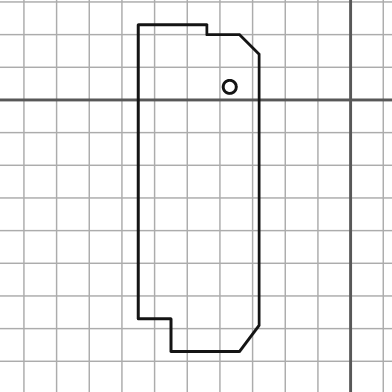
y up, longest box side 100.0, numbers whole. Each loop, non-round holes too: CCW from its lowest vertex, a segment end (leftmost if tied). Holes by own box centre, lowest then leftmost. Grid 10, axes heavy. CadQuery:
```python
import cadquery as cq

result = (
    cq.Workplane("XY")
    .moveTo(-55.0, -77.0)
    .lineTo(-34.0, -77.0)
    .lineTo(-28.0, -69.0)
    .lineTo(-28.0, 14.0)
    .lineTo(-34.0, 20.0)
    .lineTo(-44.0, 20.0)
    .lineTo(-44.0, 23.0)
    .lineTo(-65.0, 23.0)
    .lineTo(-65.0, -67.0)
    .lineTo(-55.0, -67.0)
    .close()
    .moveTo(-37.0, 4.0)
    .circle(2.0)
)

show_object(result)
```